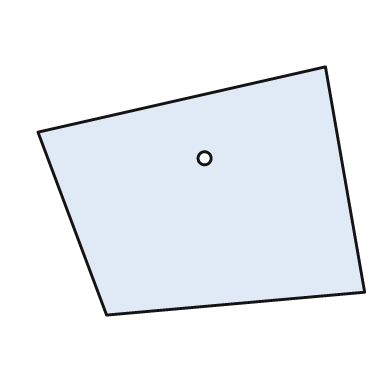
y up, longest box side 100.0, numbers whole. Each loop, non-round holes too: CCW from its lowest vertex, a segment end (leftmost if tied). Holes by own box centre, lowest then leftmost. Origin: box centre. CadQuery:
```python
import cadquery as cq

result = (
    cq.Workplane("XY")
    .moveTo(-29.0, -38.0)
    .lineTo(50.0, -31.0)
    .lineTo(38.0, 38.0)
    .lineTo(-50.0, 18.0)
    .close()
    .moveTo(1.0, 10.0)
    .circle(2.0)
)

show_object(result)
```